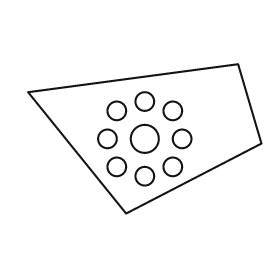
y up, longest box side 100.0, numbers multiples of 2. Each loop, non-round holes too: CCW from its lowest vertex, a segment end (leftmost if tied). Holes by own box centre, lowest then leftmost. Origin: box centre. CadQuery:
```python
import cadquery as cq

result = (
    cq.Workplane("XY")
    .moveTo(-8.0, -32.0)
    .lineTo(50.0, -2.0)
    .lineTo(40.0, 32.0)
    .lineTo(-50.0, 20.0)
    .close()
    .moveTo(0.0, -16.0)
    .circle(4.0)
    .moveTo(-12.0, -12.0)
    .circle(4.0)
    .moveTo(12.0, -12.0)
    .circle(4.0)
    .moveTo(-16.0, 0.0)
    .circle(4.0)
    .moveTo(0.0, 0.0)
    .circle(6.0)
    .moveTo(16.0, 0.0)
    .circle(4.0)
    .moveTo(-12.0, 12.0)
    .circle(4.0)
    .moveTo(12.0, 12.0)
    .circle(4.0)
    .moveTo(0.0, 16.0)
    .circle(4.0)
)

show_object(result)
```